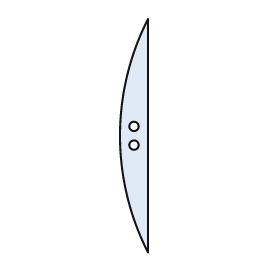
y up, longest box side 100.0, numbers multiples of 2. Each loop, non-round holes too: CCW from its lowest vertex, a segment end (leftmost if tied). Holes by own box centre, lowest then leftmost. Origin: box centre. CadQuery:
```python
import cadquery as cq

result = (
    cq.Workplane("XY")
    .moveTo(6.0, -50.0)
    .lineTo(6.0, 50.0)
    .threePointArc((-6.0, 0.0), (6.0, -50.0))
    .close()
    .moveTo(0.0, -4.0)
    .circle(2.0)
    .moveTo(0.0, 4.0)
    .circle(2.0)
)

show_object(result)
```